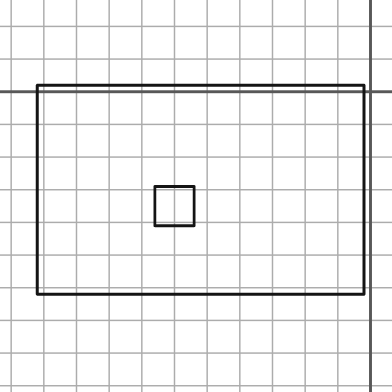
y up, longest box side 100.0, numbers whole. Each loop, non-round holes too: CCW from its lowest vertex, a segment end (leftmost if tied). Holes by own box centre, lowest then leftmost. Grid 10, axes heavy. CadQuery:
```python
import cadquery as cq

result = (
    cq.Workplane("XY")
    .moveTo(-102.0, -62.0)
    .lineTo(-2.0, -62.0)
    .lineTo(-2.0, 2.0)
    .lineTo(-102.0, 2.0)
    .close()
    .moveTo(-66.0, -41.0)
    .lineTo(-54.0, -41.0)
    .lineTo(-54.0, -29.0)
    .lineTo(-66.0, -29.0)
    .close()
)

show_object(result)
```